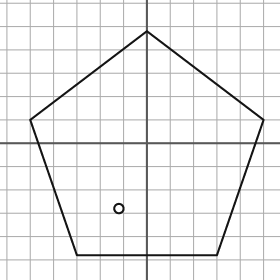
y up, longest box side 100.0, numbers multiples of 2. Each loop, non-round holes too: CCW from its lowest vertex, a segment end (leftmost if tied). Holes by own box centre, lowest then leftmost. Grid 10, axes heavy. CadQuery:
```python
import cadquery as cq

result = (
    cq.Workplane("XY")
    .moveTo(-30.0, -48.0)
    .lineTo(30.0, -48.0)
    .lineTo(50.0, 10.0)
    .lineTo(0.0, 48.0)
    .lineTo(-50.0, 10.0)
    .close()
    .moveTo(-12.0, -28.0)
    .circle(2.0)
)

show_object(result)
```